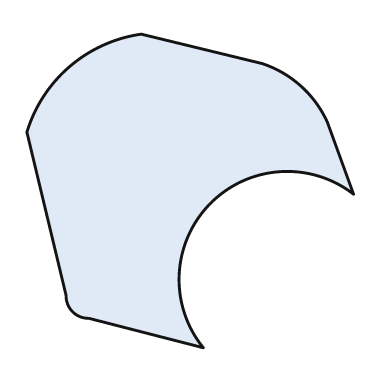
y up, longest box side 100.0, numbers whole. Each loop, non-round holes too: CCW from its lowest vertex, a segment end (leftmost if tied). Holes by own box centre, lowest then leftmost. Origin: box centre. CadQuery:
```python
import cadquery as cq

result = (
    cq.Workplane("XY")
    .moveTo(4.0, -48.0)
    .threePointArc((6.0, -4.0), (50.0, -1.0))
    .lineTo(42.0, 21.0)
    .threePointArc((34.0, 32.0), (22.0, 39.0))
    .lineTo(-15.0, 48.0)
    .threePointArc((-37.0, 38.0), (-50.0, 18.0))
    .lineTo(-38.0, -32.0)
    .threePointArc((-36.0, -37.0), (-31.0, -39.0))
    .close()
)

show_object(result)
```